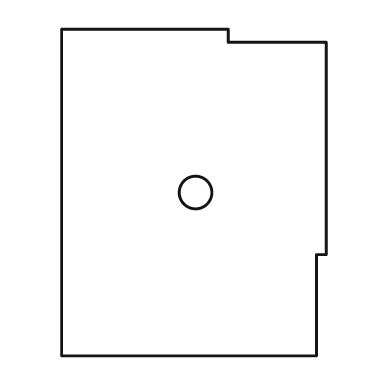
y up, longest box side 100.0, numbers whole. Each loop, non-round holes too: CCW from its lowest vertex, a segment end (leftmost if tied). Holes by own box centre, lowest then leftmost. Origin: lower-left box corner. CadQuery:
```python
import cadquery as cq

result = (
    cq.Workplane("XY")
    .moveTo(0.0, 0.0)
    .lineTo(78.0, 0.0)
    .lineTo(78.0, 31.0)
    .lineTo(81.0, 31.0)
    .lineTo(81.0, 96.0)
    .lineTo(51.0, 96.0)
    .lineTo(51.0, 100.0)
    .lineTo(0.0, 100.0)
    .close()
    .moveTo(41.0, 50.0)
    .circle(5.0)
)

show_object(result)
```